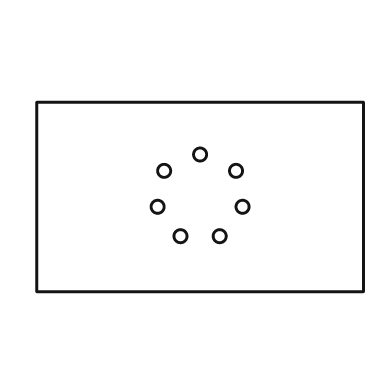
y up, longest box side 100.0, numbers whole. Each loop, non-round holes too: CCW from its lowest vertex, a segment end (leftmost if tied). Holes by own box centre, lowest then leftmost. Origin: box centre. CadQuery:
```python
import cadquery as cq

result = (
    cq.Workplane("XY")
    .moveTo(-50.0, -29.0)
    .lineTo(50.0, -29.0)
    .lineTo(50.0, 29.0)
    .lineTo(-50.0, 29.0)
    .close()
    .moveTo(-6.0, -12.0)
    .circle(2.0)
    .moveTo(6.0, -12.0)
    .circle(2.0)
    .moveTo(-13.0, -3.0)
    .circle(2.0)
    .moveTo(13.0, -3.0)
    .circle(2.0)
    .moveTo(-11.0, 8.0)
    .circle(2.0)
    .moveTo(11.0, 8.0)
    .circle(2.0)
    .moveTo(0.0, 13.0)
    .circle(2.0)
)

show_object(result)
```